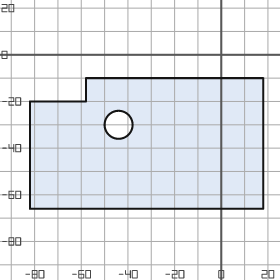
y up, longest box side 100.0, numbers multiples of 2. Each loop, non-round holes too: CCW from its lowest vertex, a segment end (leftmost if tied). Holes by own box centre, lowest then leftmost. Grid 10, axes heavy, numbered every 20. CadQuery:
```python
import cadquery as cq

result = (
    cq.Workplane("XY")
    .moveTo(-82.0, -66.0)
    .lineTo(18.0, -66.0)
    .lineTo(18.0, -10.0)
    .lineTo(-58.0, -10.0)
    .lineTo(-58.0, -20.0)
    .lineTo(-82.0, -20.0)
    .close()
    .moveTo(-44.0, -30.0)
    .circle(6.0)
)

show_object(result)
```